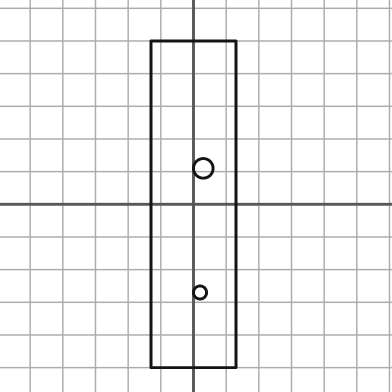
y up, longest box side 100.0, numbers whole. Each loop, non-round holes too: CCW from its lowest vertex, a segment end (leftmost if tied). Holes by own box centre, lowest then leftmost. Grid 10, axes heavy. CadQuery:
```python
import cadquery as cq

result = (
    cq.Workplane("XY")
    .moveTo(-13.0, -50.0)
    .lineTo(13.0, -50.0)
    .lineTo(13.0, 50.0)
    .lineTo(-13.0, 50.0)
    .close()
    .moveTo(2.0, -27.0)
    .circle(2.0)
    .moveTo(3.0, 11.0)
    .circle(3.0)
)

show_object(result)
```